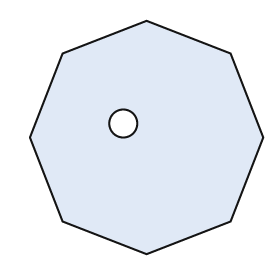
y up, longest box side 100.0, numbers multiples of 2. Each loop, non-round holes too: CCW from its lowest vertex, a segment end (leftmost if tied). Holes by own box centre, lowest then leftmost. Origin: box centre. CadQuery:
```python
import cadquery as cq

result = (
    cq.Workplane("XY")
    .moveTo(0.0, -50.0)
    .lineTo(36.0, -36.0)
    .lineTo(50.0, 0.0)
    .lineTo(36.0, 36.0)
    .lineTo(0.0, 50.0)
    .lineTo(-36.0, 36.0)
    .lineTo(-50.0, 0.0)
    .lineTo(-36.0, -36.0)
    .close()
    .moveTo(-10.0, 6.0)
    .circle(6.0)
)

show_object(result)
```